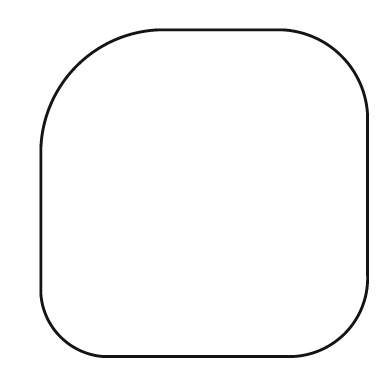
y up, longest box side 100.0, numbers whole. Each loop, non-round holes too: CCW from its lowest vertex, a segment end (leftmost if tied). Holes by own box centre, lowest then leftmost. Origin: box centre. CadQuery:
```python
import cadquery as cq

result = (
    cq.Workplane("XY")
    .moveTo(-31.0, -50.0)
    .lineTo(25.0, -50.0)
    .threePointArc((43.0, -43.0), (50.0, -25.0))
    .lineTo(50.0, 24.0)
    .threePointArc((42.0, 42.0), (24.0, 50.0))
    .lineTo(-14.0, 50.0)
    .threePointArc((-39.0, 39.0), (-50.0, 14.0))
    .lineTo(-50.0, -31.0)
    .threePointArc((-44.0, -44.0), (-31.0, -50.0))
    .close()
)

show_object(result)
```